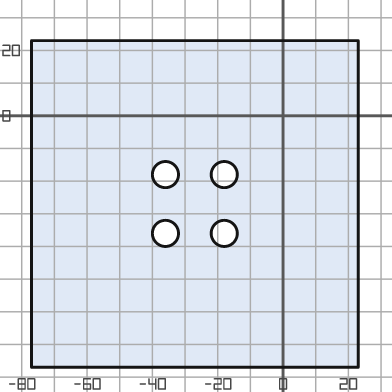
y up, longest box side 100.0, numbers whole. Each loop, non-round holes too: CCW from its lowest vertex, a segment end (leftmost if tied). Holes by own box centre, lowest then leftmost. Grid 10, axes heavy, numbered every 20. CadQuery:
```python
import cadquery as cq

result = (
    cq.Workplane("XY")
    .moveTo(-77.0, -77.0)
    .lineTo(23.0, -77.0)
    .lineTo(23.0, 23.0)
    .lineTo(-77.0, 23.0)
    .close()
    .moveTo(-36.0, -36.0)
    .circle(4.0)
    .moveTo(-18.0, -36.0)
    .circle(4.0)
    .moveTo(-36.0, -18.0)
    .circle(4.0)
    .moveTo(-18.0, -18.0)
    .circle(4.0)
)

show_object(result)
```